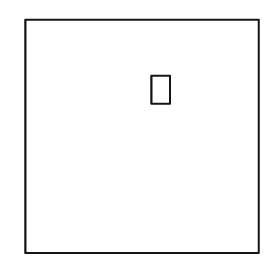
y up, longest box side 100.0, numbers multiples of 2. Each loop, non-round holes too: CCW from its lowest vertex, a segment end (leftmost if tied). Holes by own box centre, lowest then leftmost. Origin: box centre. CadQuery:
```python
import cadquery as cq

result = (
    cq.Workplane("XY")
    .moveTo(-50.0, -50.0)
    .lineTo(50.0, -50.0)
    .lineTo(50.0, 50.0)
    .lineTo(-50.0, 50.0)
    .close()
    .moveTo(4.0, 14.0)
    .lineTo(12.0, 14.0)
    .lineTo(12.0, 26.0)
    .lineTo(4.0, 26.0)
    .close()
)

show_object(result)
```